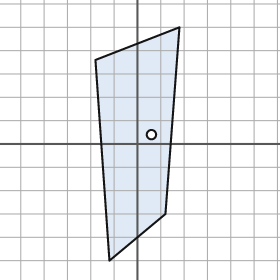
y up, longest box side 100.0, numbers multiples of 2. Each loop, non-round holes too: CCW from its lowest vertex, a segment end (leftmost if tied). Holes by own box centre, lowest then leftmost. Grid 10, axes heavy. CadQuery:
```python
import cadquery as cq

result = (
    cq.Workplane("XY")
    .moveTo(-12.0, -50.0)
    .lineTo(12.0, -30.0)
    .lineTo(18.0, 50.0)
    .lineTo(-18.0, 36.0)
    .close()
    .moveTo(6.0, 4.0)
    .circle(2.0)
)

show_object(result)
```